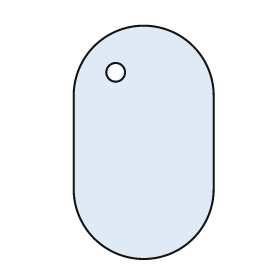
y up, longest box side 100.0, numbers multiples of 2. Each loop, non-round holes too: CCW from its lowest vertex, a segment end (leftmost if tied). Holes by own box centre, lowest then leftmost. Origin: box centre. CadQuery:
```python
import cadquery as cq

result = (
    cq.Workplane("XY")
    .moveTo(-30.0, -20.0)
    .threePointArc((0.0, -50.0), (30.0, -20.0))
    .lineTo(30.0, 20.0)
    .threePointArc((0.0, 50.0), (-30.0, 20.0))
    .close()
    .moveTo(-12.0, 30.0)
    .circle(4.0)
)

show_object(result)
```